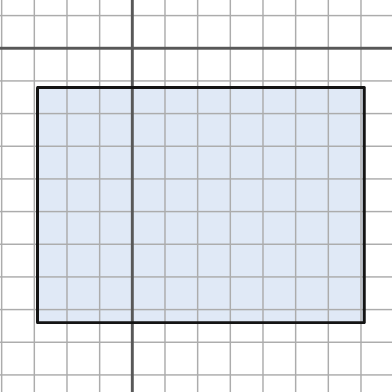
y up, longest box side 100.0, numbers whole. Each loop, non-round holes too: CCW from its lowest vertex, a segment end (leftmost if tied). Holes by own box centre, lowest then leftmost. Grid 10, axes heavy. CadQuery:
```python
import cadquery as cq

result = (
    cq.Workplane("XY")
    .moveTo(-29.0, -84.0)
    .lineTo(71.0, -84.0)
    .lineTo(71.0, -12.0)
    .lineTo(-29.0, -12.0)
    .close()
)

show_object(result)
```